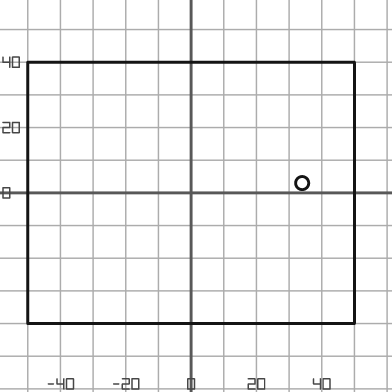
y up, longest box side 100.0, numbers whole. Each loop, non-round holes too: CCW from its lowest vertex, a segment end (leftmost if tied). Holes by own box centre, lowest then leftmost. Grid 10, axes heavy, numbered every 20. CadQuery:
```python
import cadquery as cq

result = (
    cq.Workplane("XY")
    .moveTo(-50.0, -40.0)
    .lineTo(50.0, -40.0)
    .lineTo(50.0, 40.0)
    .lineTo(-50.0, 40.0)
    .close()
    .moveTo(34.0, 3.0)
    .circle(2.0)
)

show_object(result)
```